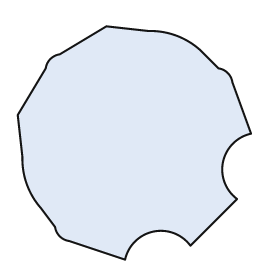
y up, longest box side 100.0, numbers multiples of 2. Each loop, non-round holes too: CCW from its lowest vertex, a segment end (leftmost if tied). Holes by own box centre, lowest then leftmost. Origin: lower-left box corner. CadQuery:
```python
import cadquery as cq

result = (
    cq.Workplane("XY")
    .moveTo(46.0, 0.0)
    .threePointArc((58.0, 12.0), (74.0, 6.0))
    .lineTo(94.0, 26.0)
    .threePointArc((88.0, 42.0), (100.0, 54.0))
    .lineTo(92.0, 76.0)
    .threePointArc((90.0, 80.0), (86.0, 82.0))
    .lineTo(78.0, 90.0)
    .threePointArc((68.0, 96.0), (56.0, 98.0))
    .lineTo(38.0, 100.0)
    .lineTo(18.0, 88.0)
    .threePointArc((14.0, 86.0), (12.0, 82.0))
    .lineTo(0.0, 62.0)
    .lineTo(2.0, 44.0)
    .threePointArc((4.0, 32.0), (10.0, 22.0))
    .lineTo(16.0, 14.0)
    .threePointArc((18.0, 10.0), (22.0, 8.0))
    .close()
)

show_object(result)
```